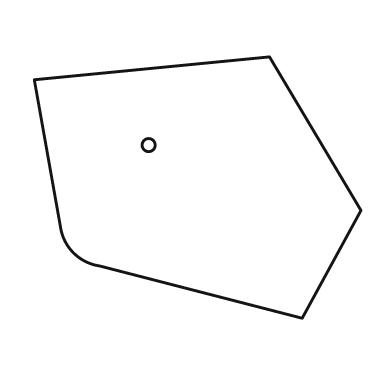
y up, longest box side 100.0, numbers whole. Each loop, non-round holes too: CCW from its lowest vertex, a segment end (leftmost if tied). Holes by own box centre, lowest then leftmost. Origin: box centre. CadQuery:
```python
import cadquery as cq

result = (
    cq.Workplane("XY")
    .moveTo(32.0, -40.0)
    .lineTo(50.0, -7.0)
    .lineTo(22.0, 40.0)
    .lineTo(-50.0, 33.0)
    .lineTo(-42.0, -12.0)
    .threePointArc((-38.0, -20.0), (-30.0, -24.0))
    .close()
    .moveTo(-15.0, 13.0)
    .circle(2.0)
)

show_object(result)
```